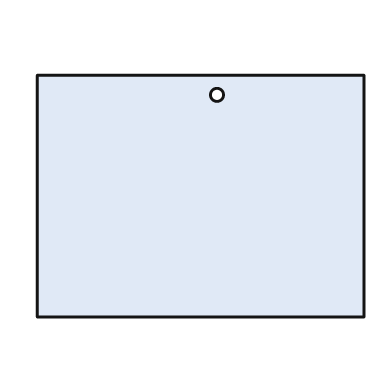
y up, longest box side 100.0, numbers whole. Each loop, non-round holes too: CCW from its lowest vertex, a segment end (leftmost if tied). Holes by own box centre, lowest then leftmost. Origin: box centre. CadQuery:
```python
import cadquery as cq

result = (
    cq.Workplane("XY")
    .moveTo(-50.0, -37.0)
    .lineTo(50.0, -37.0)
    .lineTo(50.0, 37.0)
    .lineTo(-50.0, 37.0)
    .close()
    .moveTo(5.0, 31.0)
    .circle(2.0)
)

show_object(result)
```